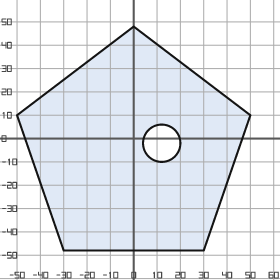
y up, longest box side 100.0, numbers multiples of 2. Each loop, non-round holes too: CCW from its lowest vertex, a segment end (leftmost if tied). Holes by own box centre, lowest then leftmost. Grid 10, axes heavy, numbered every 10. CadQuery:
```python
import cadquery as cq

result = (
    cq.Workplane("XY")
    .moveTo(-30.0, -48.0)
    .lineTo(30.0, -48.0)
    .lineTo(50.0, 10.0)
    .lineTo(0.0, 48.0)
    .lineTo(-50.0, 10.0)
    .close()
    .moveTo(12.0, -2.0)
    .circle(8.0)
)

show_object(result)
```